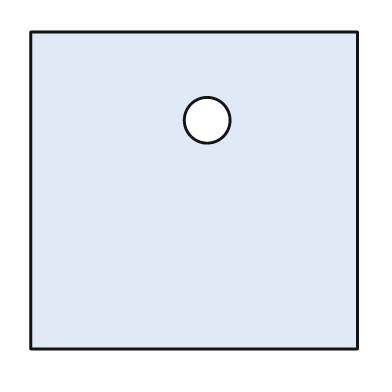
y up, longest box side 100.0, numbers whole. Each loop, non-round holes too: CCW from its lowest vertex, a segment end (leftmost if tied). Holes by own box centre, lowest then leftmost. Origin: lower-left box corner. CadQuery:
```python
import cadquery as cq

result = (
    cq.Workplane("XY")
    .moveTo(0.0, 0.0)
    .lineTo(100.0, 0.0)
    .lineTo(100.0, 97.0)
    .lineTo(0.0, 97.0)
    .close()
    .moveTo(54.0, 70.0)
    .circle(7.0)
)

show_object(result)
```